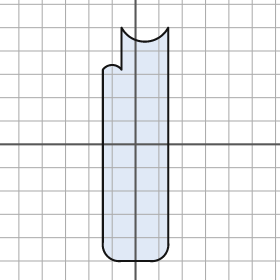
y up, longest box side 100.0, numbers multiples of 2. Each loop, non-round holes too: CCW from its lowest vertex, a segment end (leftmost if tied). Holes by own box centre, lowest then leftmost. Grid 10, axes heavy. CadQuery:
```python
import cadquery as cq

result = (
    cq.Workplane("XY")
    .moveTo(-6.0, -50.0)
    .lineTo(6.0, -50.0)
    .threePointArc((12.0, -48.0), (14.0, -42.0))
    .lineTo(14.0, 50.0)
    .threePointArc((4.0, 44.0), (-6.0, 50.0))
    .lineTo(-6.0, 32.0)
    .threePointArc((-10.0, 34.0), (-14.0, 32.0))
    .lineTo(-14.0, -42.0)
    .threePointArc((-12.0, -48.0), (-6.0, -50.0))
    .close()
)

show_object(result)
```